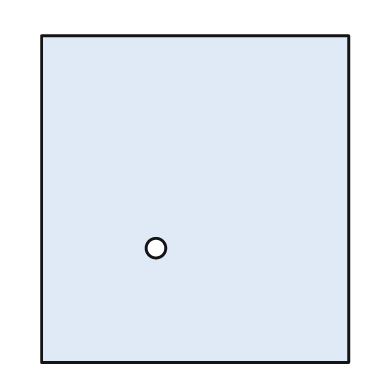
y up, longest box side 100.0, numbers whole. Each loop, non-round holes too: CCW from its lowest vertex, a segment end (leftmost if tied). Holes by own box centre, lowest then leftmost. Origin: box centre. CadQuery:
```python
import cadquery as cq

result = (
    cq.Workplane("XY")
    .moveTo(-47.0, -50.0)
    .lineTo(47.0, -50.0)
    .lineTo(47.0, 50.0)
    .lineTo(-47.0, 50.0)
    .close()
    .moveTo(-12.0, -15.0)
    .circle(3.0)
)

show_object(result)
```